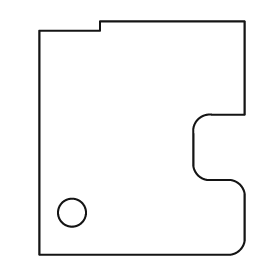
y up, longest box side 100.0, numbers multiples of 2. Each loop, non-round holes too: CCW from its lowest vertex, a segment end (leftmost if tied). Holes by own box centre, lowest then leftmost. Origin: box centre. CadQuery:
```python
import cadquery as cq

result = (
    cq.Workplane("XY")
    .moveTo(-44.0, -50.0)
    .lineTo(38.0, -50.0)
    .threePointArc((42.0, -48.0), (44.0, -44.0))
    .lineTo(44.0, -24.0)
    .threePointArc((42.0, -20.0), (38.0, -18.0))
    .lineTo(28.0, -18.0)
    .threePointArc((24.0, -16.0), (22.0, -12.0))
    .lineTo(22.0, 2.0)
    .threePointArc((24.0, 8.0), (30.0, 10.0))
    .lineTo(44.0, 10.0)
    .lineTo(44.0, 50.0)
    .lineTo(-18.0, 50.0)
    .lineTo(-18.0, 46.0)
    .lineTo(-44.0, 46.0)
    .close()
    .moveTo(-30.0, -32.0)
    .circle(6.0)
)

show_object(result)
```